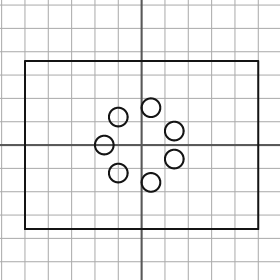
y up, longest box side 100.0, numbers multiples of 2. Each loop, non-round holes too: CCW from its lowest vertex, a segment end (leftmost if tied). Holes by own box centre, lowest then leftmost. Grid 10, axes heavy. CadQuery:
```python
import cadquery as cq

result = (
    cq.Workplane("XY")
    .moveTo(-50.0, -36.0)
    .lineTo(50.0, -36.0)
    .lineTo(50.0, 36.0)
    .lineTo(-50.0, 36.0)
    .close()
    .moveTo(4.0, -16.0)
    .circle(4.0)
    .moveTo(-10.0, -12.0)
    .circle(4.0)
    .moveTo(14.0, -6.0)
    .circle(4.0)
    .moveTo(-16.0, 0.0)
    .circle(4.0)
    .moveTo(14.0, 6.0)
    .circle(4.0)
    .moveTo(-10.0, 12.0)
    .circle(4.0)
    .moveTo(4.0, 16.0)
    .circle(4.0)
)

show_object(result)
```